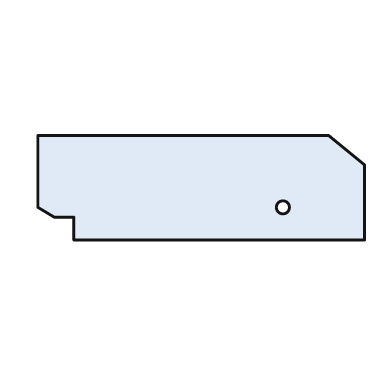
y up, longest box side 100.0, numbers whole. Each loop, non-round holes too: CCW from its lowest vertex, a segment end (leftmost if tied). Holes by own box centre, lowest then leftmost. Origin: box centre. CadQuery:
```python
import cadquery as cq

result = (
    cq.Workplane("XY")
    .moveTo(-39.0, -16.0)
    .lineTo(50.0, -16.0)
    .lineTo(50.0, 7.0)
    .lineTo(39.0, 16.0)
    .lineTo(-50.0, 16.0)
    .lineTo(-50.0, -6.0)
    .lineTo(-45.0, -9.0)
    .lineTo(-39.0, -9.0)
    .close()
    .moveTo(25.0, -6.0)
    .circle(2.0)
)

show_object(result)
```